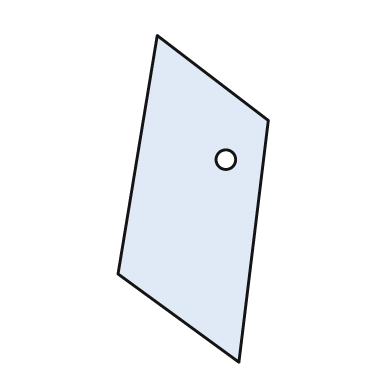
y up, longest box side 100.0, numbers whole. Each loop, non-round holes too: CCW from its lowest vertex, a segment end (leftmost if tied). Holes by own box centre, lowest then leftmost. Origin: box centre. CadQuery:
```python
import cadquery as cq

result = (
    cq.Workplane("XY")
    .moveTo(14.0, -50.0)
    .lineTo(23.0, 24.0)
    .lineTo(-11.0, 50.0)
    .lineTo(-23.0, -23.0)
    .close()
    .moveTo(10.0, 12.0)
    .circle(3.0)
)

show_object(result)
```